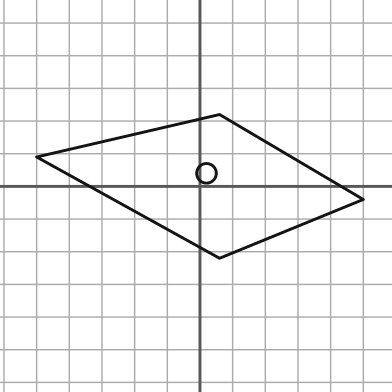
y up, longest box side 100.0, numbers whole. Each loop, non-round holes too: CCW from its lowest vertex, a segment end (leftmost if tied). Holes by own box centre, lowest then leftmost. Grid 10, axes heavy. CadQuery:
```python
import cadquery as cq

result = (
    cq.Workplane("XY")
    .moveTo(6.0, -22.0)
    .lineTo(50.0, -4.0)
    .lineTo(6.0, 22.0)
    .lineTo(-50.0, 9.0)
    .close()
    .moveTo(2.0, 4.0)
    .circle(3.0)
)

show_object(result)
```